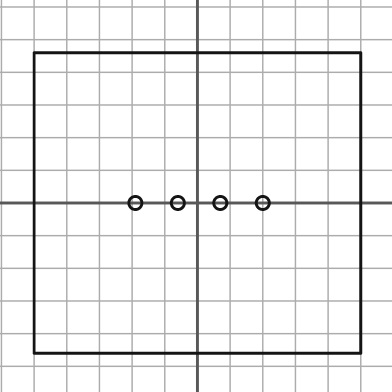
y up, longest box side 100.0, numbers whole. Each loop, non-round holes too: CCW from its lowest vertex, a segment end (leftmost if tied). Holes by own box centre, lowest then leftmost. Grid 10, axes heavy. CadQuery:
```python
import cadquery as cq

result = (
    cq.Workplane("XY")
    .moveTo(-50.0, -46.0)
    .lineTo(50.0, -46.0)
    .lineTo(50.0, 46.0)
    .lineTo(-50.0, 46.0)
    .close()
    .moveTo(-19.0, 0.0)
    .circle(2.0)
    .moveTo(-6.0, 0.0)
    .circle(2.0)
    .moveTo(7.0, 0.0)
    .circle(2.0)
    .moveTo(20.0, 0.0)
    .circle(2.0)
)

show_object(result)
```